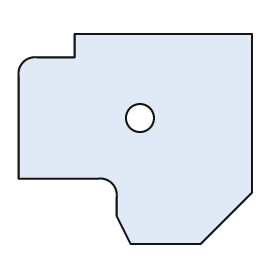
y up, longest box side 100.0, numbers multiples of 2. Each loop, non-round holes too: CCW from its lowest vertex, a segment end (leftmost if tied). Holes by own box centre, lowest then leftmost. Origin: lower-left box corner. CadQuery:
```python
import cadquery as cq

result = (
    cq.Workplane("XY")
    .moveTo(48.0, 0.0)
    .lineTo(78.0, 0.0)
    .lineTo(100.0, 22.0)
    .lineTo(100.0, 90.0)
    .lineTo(24.0, 90.0)
    .lineTo(24.0, 80.0)
    .lineTo(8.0, 80.0)
    .threePointArc((2.0, 78.0), (0.0, 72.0))
    .lineTo(0.0, 28.0)
    .lineTo(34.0, 28.0)
    .threePointArc((40.0, 26.0), (42.0, 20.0))
    .lineTo(42.0, 12.0)
    .close()
    .moveTo(52.0, 54.0)
    .circle(6.0)
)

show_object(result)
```